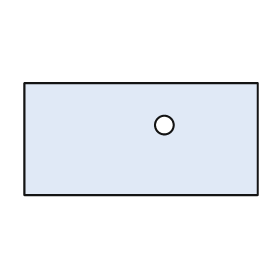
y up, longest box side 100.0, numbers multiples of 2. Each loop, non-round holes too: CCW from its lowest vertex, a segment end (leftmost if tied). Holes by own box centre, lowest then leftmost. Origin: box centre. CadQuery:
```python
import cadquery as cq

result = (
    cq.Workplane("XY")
    .moveTo(-50.0, -24.0)
    .lineTo(50.0, -24.0)
    .lineTo(50.0, 24.0)
    .lineTo(-50.0, 24.0)
    .close()
    .moveTo(10.0, 6.0)
    .circle(4.0)
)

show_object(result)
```